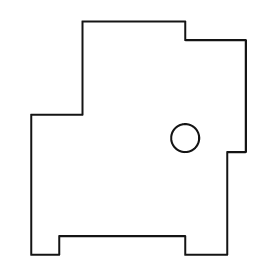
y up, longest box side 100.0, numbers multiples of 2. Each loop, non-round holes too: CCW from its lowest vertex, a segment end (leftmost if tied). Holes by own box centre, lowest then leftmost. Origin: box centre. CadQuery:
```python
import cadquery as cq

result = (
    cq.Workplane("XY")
    .moveTo(-46.0, -50.0)
    .lineTo(-34.0, -50.0)
    .lineTo(-34.0, -42.0)
    .lineTo(20.0, -42.0)
    .lineTo(20.0, -50.0)
    .lineTo(38.0, -50.0)
    .lineTo(38.0, -6.0)
    .lineTo(46.0, -6.0)
    .lineTo(46.0, 42.0)
    .lineTo(20.0, 42.0)
    .lineTo(20.0, 50.0)
    .lineTo(-24.0, 50.0)
    .lineTo(-24.0, 10.0)
    .lineTo(-46.0, 10.0)
    .close()
    .moveTo(20.0, 0.0)
    .circle(6.0)
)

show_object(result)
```